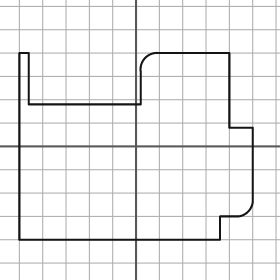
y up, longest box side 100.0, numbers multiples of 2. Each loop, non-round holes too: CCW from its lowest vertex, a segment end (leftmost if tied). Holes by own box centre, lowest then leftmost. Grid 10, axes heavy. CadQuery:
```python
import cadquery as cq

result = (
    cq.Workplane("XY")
    .moveTo(-50.0, -40.0)
    .lineTo(36.0, -40.0)
    .lineTo(36.0, -30.0)
    .lineTo(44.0, -30.0)
    .threePointArc((48.0, -28.0), (50.0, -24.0))
    .lineTo(50.0, 8.0)
    .lineTo(40.0, 8.0)
    .lineTo(40.0, 40.0)
    .lineTo(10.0, 40.0)
    .threePointArc((4.0, 38.0), (2.0, 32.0))
    .lineTo(2.0, 18.0)
    .lineTo(-46.0, 18.0)
    .lineTo(-46.0, 40.0)
    .lineTo(-50.0, 40.0)
    .close()
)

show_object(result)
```